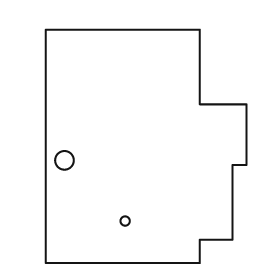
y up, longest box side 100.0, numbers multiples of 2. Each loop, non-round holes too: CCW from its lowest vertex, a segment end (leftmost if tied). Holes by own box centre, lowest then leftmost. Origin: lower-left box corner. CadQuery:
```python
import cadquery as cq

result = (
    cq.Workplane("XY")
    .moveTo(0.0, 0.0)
    .lineTo(66.0, 0.0)
    .lineTo(66.0, 10.0)
    .lineTo(80.0, 10.0)
    .lineTo(80.0, 42.0)
    .lineTo(86.0, 42.0)
    .lineTo(86.0, 68.0)
    .lineTo(66.0, 68.0)
    .lineTo(66.0, 100.0)
    .lineTo(0.0, 100.0)
    .close()
    .moveTo(34.0, 18.0)
    .circle(2.0)
    .moveTo(8.0, 44.0)
    .circle(4.0)
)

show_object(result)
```